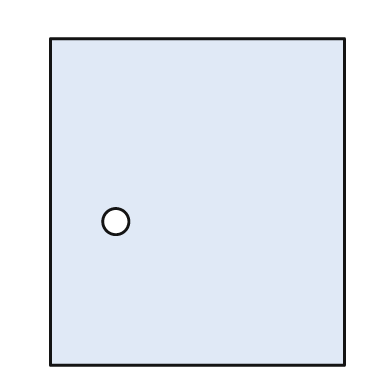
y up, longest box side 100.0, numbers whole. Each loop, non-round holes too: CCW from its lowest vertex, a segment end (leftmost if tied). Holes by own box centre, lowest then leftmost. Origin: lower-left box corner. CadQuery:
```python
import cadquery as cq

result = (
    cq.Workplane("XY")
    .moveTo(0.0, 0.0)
    .lineTo(90.0, 0.0)
    .lineTo(90.0, 100.0)
    .lineTo(0.0, 100.0)
    .close()
    .moveTo(20.0, 44.0)
    .circle(4.0)
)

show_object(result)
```